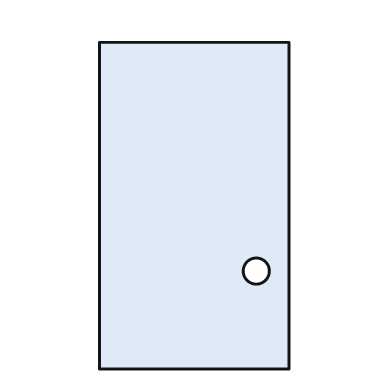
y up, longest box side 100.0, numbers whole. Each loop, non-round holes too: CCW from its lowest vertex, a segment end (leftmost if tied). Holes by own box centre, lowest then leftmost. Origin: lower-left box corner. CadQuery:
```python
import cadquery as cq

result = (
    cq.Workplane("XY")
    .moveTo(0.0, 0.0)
    .lineTo(58.0, 0.0)
    .lineTo(58.0, 100.0)
    .lineTo(0.0, 100.0)
    .close()
    .moveTo(48.0, 30.0)
    .circle(4.0)
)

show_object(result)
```